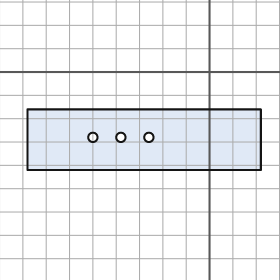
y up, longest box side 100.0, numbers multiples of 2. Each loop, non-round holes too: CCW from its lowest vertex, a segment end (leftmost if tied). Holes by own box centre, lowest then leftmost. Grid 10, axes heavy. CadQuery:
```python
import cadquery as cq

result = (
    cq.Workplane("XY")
    .moveTo(-78.0, -42.0)
    .lineTo(22.0, -42.0)
    .lineTo(22.0, -16.0)
    .lineTo(-78.0, -16.0)
    .close()
    .moveTo(-50.0, -28.0)
    .circle(2.0)
    .moveTo(-38.0, -28.0)
    .circle(2.0)
    .moveTo(-26.0, -28.0)
    .circle(2.0)
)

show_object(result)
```